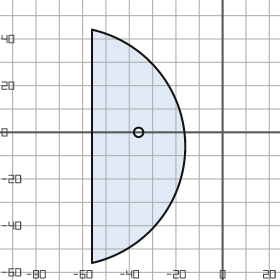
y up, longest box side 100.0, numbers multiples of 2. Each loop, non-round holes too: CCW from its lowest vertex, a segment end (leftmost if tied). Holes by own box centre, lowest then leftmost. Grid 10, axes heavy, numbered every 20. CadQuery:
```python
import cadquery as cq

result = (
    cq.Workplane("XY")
    .moveTo(-56.0, -56.0)
    .threePointArc((-16.0, -6.0), (-56.0, 44.0))
    .close()
    .moveTo(-36.0, 0.0)
    .circle(2.0)
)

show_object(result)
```